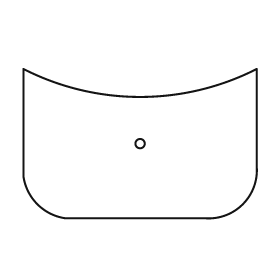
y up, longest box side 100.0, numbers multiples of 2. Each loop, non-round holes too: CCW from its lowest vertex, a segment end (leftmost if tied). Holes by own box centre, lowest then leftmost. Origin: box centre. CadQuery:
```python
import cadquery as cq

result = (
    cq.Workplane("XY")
    .moveTo(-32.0, -32.0)
    .lineTo(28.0, -32.0)
    .threePointArc((44.0, -26.0), (50.0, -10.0))
    .lineTo(50.0, 32.0)
    .threePointArc((0.0, 20.0), (-50.0, 32.0))
    .lineTo(-50.0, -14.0)
    .threePointArc((-44.0, -26.0), (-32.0, -32.0))
    .close()
    .moveTo(0.0, 0.0)
    .circle(2.0)
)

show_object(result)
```